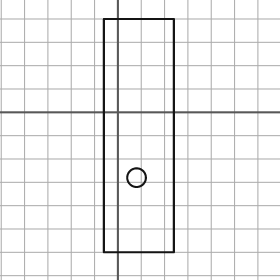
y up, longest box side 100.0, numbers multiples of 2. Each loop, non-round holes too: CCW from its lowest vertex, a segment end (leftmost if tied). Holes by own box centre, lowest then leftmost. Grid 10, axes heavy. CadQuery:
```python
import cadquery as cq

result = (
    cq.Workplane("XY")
    .moveTo(-6.0, -60.0)
    .lineTo(24.0, -60.0)
    .lineTo(24.0, 40.0)
    .lineTo(-6.0, 40.0)
    .close()
    .moveTo(8.0, -28.0)
    .circle(4.0)
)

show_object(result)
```